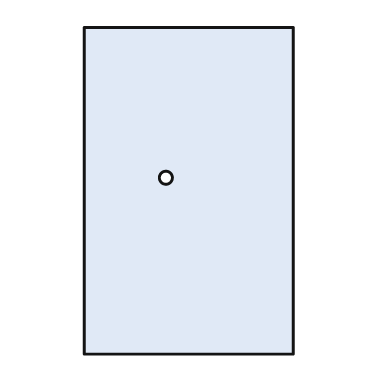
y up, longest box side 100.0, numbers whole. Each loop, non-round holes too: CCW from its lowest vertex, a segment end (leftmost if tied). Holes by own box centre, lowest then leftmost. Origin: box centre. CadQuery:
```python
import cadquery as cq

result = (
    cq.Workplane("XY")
    .moveTo(-32.0, -50.0)
    .lineTo(32.0, -50.0)
    .lineTo(32.0, 50.0)
    .lineTo(-32.0, 50.0)
    .close()
    .moveTo(-7.0, 4.0)
    .circle(2.0)
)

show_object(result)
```